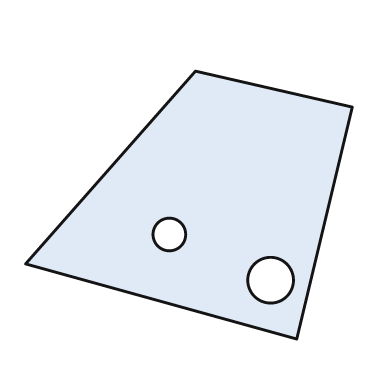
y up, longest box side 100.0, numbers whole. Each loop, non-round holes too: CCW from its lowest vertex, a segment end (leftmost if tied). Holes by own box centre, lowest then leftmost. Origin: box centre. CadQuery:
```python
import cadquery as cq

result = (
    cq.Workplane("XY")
    .moveTo(33.0, -41.0)
    .lineTo(50.0, 30.0)
    .lineTo(2.0, 41.0)
    .lineTo(-50.0, -18.0)
    .close()
    .moveTo(25.0, -23.0)
    .circle(7.0)
    .moveTo(-6.0, -9.0)
    .circle(5.0)
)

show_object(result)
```